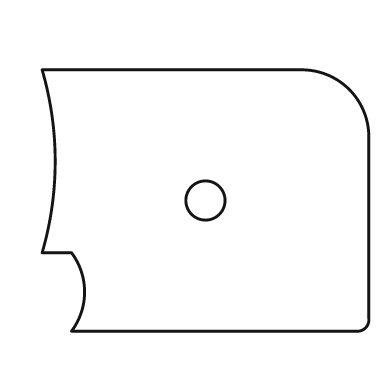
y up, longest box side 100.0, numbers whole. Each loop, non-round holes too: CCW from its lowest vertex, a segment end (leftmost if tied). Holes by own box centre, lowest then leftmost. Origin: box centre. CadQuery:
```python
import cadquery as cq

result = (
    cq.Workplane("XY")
    .moveTo(-41.0, -40.0)
    .lineTo(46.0, -40.0)
    .threePointArc((49.0, -39.0), (50.0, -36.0))
    .lineTo(50.0, 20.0)
    .threePointArc((44.0, 34.0), (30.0, 40.0))
    .lineTo(-50.0, 40.0)
    .threePointArc((-46.0, 12.0), (-50.0, -16.0))
    .lineTo(-41.0, -16.0)
    .threePointArc((-37.0, -28.0), (-41.0, -40.0))
    .close()
    .moveTo(0.0, 0.0)
    .circle(6.0)
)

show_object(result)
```